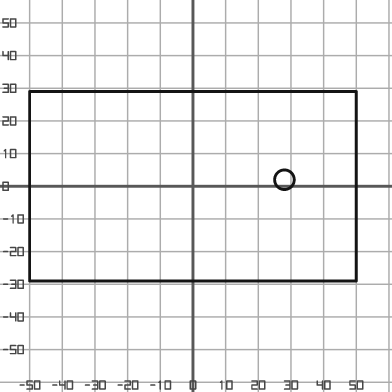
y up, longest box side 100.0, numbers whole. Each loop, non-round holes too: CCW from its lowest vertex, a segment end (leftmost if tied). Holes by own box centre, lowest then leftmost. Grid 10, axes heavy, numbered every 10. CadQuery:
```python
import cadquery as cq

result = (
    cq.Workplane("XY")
    .moveTo(-50.0, -29.0)
    .lineTo(50.0, -29.0)
    .lineTo(50.0, 29.0)
    .lineTo(-50.0, 29.0)
    .close()
    .moveTo(28.0, 2.0)
    .circle(3.0)
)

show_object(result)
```